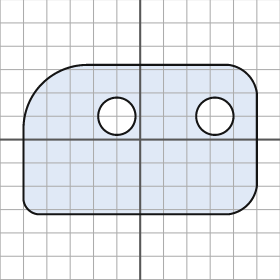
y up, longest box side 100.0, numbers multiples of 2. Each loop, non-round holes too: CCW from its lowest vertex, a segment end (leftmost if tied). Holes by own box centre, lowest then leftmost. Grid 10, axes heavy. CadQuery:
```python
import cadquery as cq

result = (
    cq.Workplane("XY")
    .moveTo(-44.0, -32.0)
    .lineTo(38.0, -32.0)
    .threePointArc((46.0, -28.0), (50.0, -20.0))
    .lineTo(50.0, 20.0)
    .threePointArc((46.0, 28.0), (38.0, 32.0))
    .lineTo(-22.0, 32.0)
    .threePointArc((-42.0, 24.0), (-50.0, 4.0))
    .lineTo(-50.0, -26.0)
    .threePointArc((-48.0, -30.0), (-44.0, -32.0))
    .close()
    .moveTo(-10.0, 10.0)
    .circle(8.0)
    .moveTo(32.0, 10.0)
    .circle(8.0)
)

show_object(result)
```